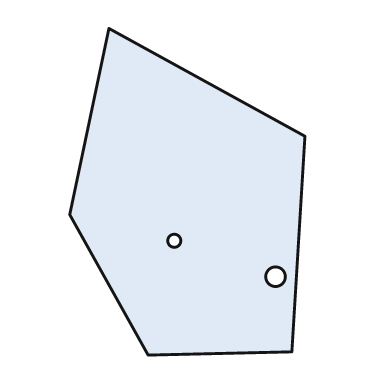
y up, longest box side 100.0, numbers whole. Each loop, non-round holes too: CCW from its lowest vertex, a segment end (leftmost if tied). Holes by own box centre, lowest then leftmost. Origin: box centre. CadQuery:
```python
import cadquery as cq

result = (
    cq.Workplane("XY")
    .moveTo(-12.0, -50.0)
    .lineTo(32.0, -49.0)
    .lineTo(36.0, 17.0)
    .lineTo(-24.0, 50.0)
    .lineTo(-36.0, -7.0)
    .close()
    .moveTo(27.0, -26.0)
    .circle(3.0)
    .moveTo(-4.0, -15.0)
    .circle(2.0)
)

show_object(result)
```